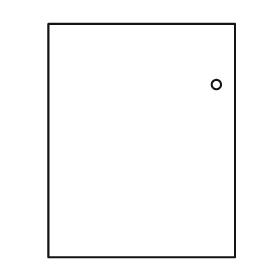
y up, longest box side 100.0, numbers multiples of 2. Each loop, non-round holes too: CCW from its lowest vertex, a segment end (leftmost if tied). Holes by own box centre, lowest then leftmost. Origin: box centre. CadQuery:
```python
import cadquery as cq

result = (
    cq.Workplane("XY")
    .moveTo(-40.0, -50.0)
    .lineTo(40.0, -50.0)
    .lineTo(40.0, 50.0)
    .lineTo(-40.0, 50.0)
    .close()
    .moveTo(32.0, 24.0)
    .circle(2.0)
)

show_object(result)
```